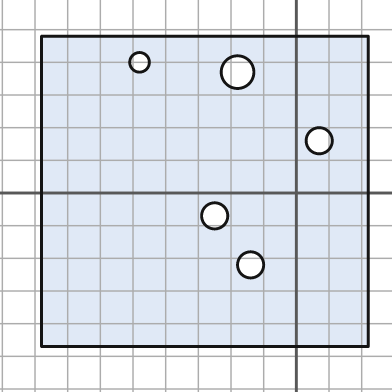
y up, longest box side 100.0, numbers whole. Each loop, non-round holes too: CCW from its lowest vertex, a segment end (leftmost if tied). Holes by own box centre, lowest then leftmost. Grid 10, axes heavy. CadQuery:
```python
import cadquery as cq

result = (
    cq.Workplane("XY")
    .moveTo(-78.0, -47.0)
    .lineTo(22.0, -47.0)
    .lineTo(22.0, 48.0)
    .lineTo(-78.0, 48.0)
    .close()
    .moveTo(-14.0, -22.0)
    .circle(4.0)
    .moveTo(-25.0, -7.0)
    .circle(4.0)
    .moveTo(7.0, 16.0)
    .circle(4.0)
    .moveTo(-18.0, 37.0)
    .circle(5.0)
    .moveTo(-48.0, 40.0)
    .circle(3.0)
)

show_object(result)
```